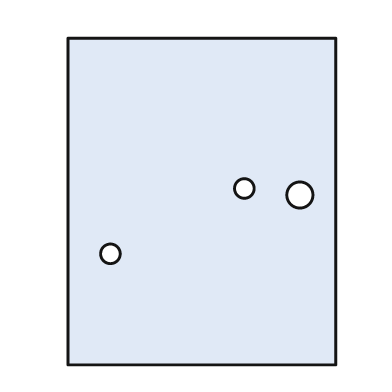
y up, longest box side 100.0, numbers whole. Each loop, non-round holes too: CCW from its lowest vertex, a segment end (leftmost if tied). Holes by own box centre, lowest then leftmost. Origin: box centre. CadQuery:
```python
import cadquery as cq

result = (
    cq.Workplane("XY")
    .moveTo(-41.0, -50.0)
    .lineTo(41.0, -50.0)
    .lineTo(41.0, 50.0)
    .lineTo(-41.0, 50.0)
    .close()
    .moveTo(-28.0, -16.0)
    .circle(3.0)
    .moveTo(30.0, 2.0)
    .circle(4.0)
    .moveTo(13.0, 4.0)
    .circle(3.0)
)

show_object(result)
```